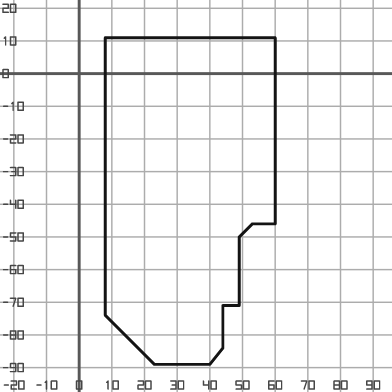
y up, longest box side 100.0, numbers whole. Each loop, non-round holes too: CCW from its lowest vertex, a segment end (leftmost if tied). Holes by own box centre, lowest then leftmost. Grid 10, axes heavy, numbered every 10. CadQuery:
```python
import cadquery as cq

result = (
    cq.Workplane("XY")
    .moveTo(23.0, -89.0)
    .lineTo(40.0, -89.0)
    .lineTo(44.0, -84.0)
    .lineTo(44.0, -71.0)
    .lineTo(49.0, -71.0)
    .lineTo(49.0, -50.0)
    .lineTo(53.0, -46.0)
    .lineTo(60.0, -46.0)
    .lineTo(60.0, 11.0)
    .lineTo(8.0, 11.0)
    .lineTo(8.0, -74.0)
    .close()
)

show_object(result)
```